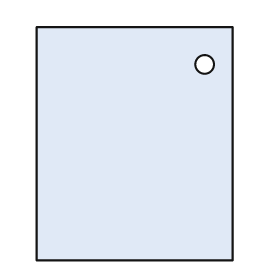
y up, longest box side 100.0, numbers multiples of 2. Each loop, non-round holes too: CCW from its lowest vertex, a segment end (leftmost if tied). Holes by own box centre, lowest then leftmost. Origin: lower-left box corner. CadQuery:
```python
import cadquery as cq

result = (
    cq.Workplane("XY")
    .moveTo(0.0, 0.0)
    .lineTo(84.0, 0.0)
    .lineTo(84.0, 100.0)
    .lineTo(0.0, 100.0)
    .close()
    .moveTo(72.0, 84.0)
    .circle(4.0)
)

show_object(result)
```